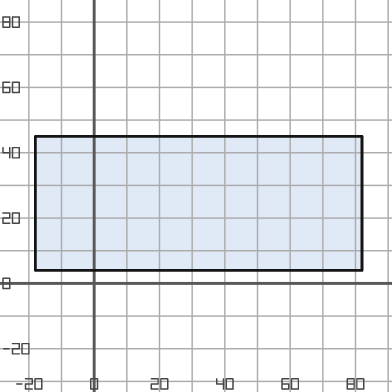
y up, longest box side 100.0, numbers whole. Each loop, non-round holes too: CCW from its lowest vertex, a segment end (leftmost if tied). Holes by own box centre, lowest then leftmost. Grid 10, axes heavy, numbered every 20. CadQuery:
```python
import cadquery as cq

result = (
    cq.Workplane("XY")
    .moveTo(-18.0, 4.0)
    .lineTo(82.0, 4.0)
    .lineTo(82.0, 45.0)
    .lineTo(-18.0, 45.0)
    .close()
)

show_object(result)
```